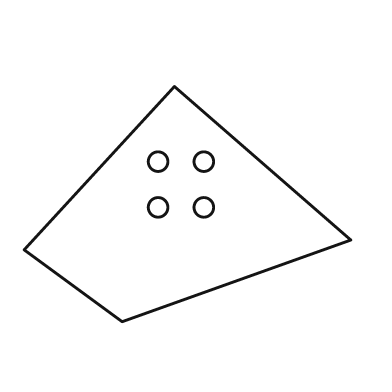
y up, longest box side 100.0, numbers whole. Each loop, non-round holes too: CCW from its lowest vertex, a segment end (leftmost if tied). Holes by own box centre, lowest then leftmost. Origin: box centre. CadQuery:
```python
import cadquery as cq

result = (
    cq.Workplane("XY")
    .moveTo(-20.0, -36.0)
    .lineTo(50.0, -11.0)
    .lineTo(-4.0, 36.0)
    .lineTo(-50.0, -14.0)
    .close()
    .moveTo(-9.0, -1.0)
    .circle(3.0)
    .moveTo(5.0, -1.0)
    .circle(3.0)
    .moveTo(-9.0, 13.0)
    .circle(3.0)
    .moveTo(5.0, 13.0)
    .circle(3.0)
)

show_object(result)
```